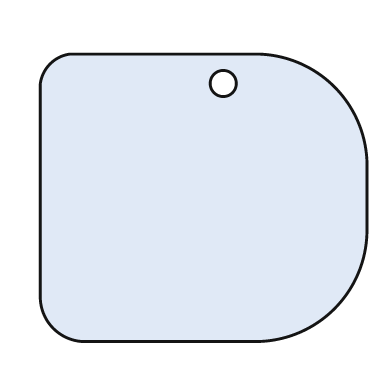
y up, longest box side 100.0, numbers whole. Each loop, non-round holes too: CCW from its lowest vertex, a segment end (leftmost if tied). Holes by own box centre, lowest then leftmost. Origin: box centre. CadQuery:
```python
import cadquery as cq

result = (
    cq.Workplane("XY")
    .moveTo(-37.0, -44.0)
    .lineTo(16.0, -44.0)
    .threePointArc((40.0, -34.0), (50.0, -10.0))
    .lineTo(50.0, 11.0)
    .threePointArc((40.0, 34.0), (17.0, 44.0))
    .lineTo(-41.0, 44.0)
    .threePointArc((-47.0, 41.0), (-50.0, 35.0))
    .lineTo(-50.0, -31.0)
    .threePointArc((-46.0, -40.0), (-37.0, -44.0))
    .close()
    .moveTo(6.0, 35.0)
    .circle(4.0)
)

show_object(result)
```